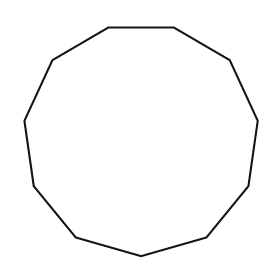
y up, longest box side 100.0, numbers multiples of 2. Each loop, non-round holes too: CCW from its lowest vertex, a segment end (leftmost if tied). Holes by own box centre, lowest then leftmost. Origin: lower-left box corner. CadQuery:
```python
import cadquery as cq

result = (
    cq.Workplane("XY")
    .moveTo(50.0, 0.0)
    .lineTo(78.0, 8.0)
    .lineTo(96.0, 30.0)
    .lineTo(100.0, 58.0)
    .lineTo(88.0, 84.0)
    .lineTo(64.0, 98.0)
    .lineTo(36.0, 98.0)
    .lineTo(12.0, 84.0)
    .lineTo(0.0, 58.0)
    .lineTo(4.0, 30.0)
    .lineTo(22.0, 8.0)
    .close()
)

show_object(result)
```